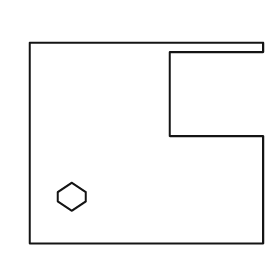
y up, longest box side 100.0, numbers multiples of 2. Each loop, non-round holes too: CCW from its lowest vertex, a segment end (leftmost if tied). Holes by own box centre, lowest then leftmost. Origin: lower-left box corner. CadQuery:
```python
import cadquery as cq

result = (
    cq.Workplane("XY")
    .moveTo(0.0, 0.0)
    .lineTo(100.0, 0.0)
    .lineTo(100.0, 46.0)
    .lineTo(60.0, 46.0)
    .lineTo(60.0, 82.0)
    .lineTo(100.0, 82.0)
    .lineTo(100.0, 86.0)
    .lineTo(0.0, 86.0)
    .close()
    .moveTo(18.0, 14.0)
    .lineTo(24.0, 18.0)
    .lineTo(24.0, 22.0)
    .lineTo(18.0, 26.0)
    .lineTo(12.0, 22.0)
    .lineTo(12.0, 18.0)
    .close()
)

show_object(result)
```